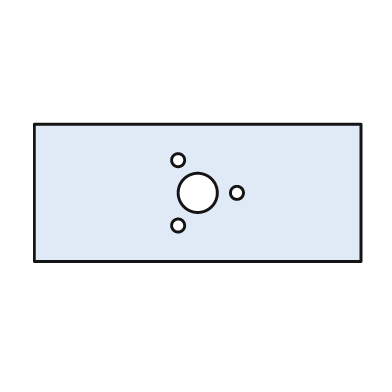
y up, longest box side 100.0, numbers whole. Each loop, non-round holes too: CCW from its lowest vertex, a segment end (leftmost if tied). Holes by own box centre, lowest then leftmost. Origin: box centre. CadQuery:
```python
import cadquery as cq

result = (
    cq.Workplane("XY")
    .moveTo(-50.0, -21.0)
    .lineTo(50.0, -21.0)
    .lineTo(50.0, 21.0)
    .lineTo(-50.0, 21.0)
    .close()
    .moveTo(-6.0, -10.0)
    .circle(2.0)
    .moveTo(0.0, 0.0)
    .circle(6.0)
    .moveTo(12.0, 0.0)
    .circle(2.0)
    .moveTo(-6.0, 10.0)
    .circle(2.0)
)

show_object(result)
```